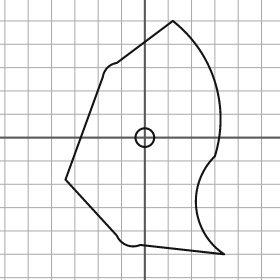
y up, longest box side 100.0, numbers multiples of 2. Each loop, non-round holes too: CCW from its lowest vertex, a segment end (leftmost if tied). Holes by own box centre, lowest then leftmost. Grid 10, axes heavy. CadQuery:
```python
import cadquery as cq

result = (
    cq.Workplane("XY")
    .moveTo(34.0, -50.0)
    .threePointArc((22.0, -30.0), (30.0, -8.0))
    .threePointArc((30.0, 24.0), (12.0, 50.0))
    .lineTo(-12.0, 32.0)
    .threePointArc((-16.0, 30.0), (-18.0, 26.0))
    .lineTo(-34.0, -18.0)
    .lineTo(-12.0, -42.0)
    .threePointArc((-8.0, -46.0), (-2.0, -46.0))
    .close()
    .moveTo(0.0, 0.0)
    .circle(4.0)
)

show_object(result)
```